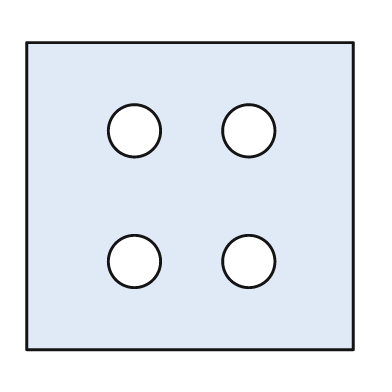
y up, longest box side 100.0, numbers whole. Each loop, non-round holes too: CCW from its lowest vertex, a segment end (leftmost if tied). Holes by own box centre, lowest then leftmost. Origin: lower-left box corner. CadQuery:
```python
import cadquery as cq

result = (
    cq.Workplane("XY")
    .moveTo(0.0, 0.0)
    .lineTo(100.0, 0.0)
    .lineTo(100.0, 94.0)
    .lineTo(0.0, 94.0)
    .close()
    .moveTo(33.0, 27.0)
    .circle(8.0)
    .moveTo(68.0, 27.0)
    .circle(8.0)
    .moveTo(33.0, 67.0)
    .circle(8.0)
    .moveTo(68.0, 67.0)
    .circle(8.0)
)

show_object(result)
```